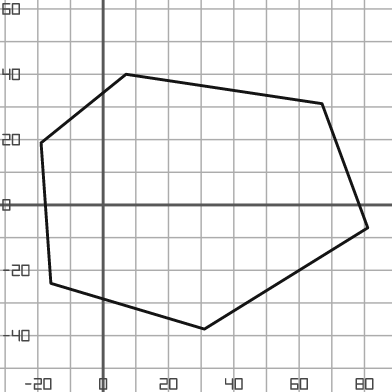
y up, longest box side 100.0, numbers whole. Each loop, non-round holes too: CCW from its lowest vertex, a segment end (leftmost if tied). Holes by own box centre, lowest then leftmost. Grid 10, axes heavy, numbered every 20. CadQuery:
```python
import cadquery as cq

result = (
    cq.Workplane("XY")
    .moveTo(31.0, -38.0)
    .lineTo(81.0, -7.0)
    .lineTo(67.0, 31.0)
    .lineTo(7.0, 40.0)
    .lineTo(-19.0, 19.0)
    .lineTo(-16.0, -24.0)
    .close()
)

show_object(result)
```